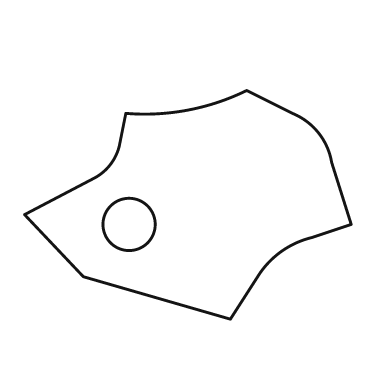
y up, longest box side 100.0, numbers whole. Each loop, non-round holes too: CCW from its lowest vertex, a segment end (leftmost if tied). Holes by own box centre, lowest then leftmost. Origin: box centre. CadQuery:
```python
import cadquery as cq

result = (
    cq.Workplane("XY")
    .moveTo(13.0, -35.0)
    .lineTo(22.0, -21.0)
    .threePointArc((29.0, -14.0), (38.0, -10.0))
    .lineTo(50.0, -6.0)
    .lineTo(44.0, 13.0)
    .threePointArc((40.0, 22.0), (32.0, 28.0))
    .lineTo(18.0, 35.0)
    .threePointArc((0.0, 29.0), (-19.0, 28.0))
    .lineTo(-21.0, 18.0)
    .threePointArc((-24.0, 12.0), (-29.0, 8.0))
    .lineTo(-50.0, -3.0)
    .lineTo(-32.0, -22.0)
    .close()
    .moveTo(-18.0, -6.0)
    .circle(8.0)
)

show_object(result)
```